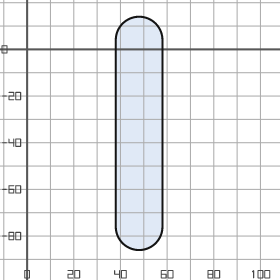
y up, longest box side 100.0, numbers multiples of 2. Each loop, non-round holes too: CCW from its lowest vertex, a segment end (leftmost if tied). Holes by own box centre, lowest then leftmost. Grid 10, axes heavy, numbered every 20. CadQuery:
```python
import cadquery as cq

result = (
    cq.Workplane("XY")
    .moveTo(38.0, -76.0)
    .threePointArc((48.0, -86.0), (58.0, -76.0))
    .lineTo(58.0, 4.0)
    .threePointArc((48.0, 14.0), (38.0, 4.0))
    .close()
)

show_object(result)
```